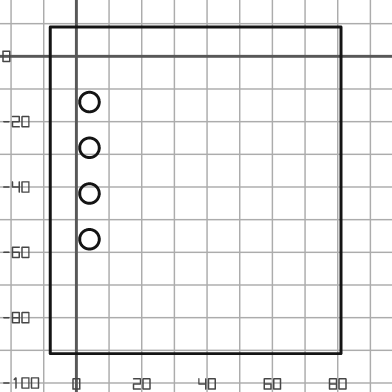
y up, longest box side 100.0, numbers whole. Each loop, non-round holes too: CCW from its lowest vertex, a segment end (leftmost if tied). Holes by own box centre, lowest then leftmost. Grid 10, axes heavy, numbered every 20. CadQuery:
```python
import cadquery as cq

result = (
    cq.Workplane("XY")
    .moveTo(-8.0, -91.0)
    .lineTo(81.0, -91.0)
    .lineTo(81.0, 9.0)
    .lineTo(-8.0, 9.0)
    .close()
    .moveTo(4.0, -56.0)
    .circle(3.0)
    .moveTo(4.0, -42.0)
    .circle(3.0)
    .moveTo(4.0, -28.0)
    .circle(3.0)
    .moveTo(4.0, -14.0)
    .circle(3.0)
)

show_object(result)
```